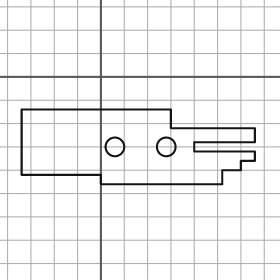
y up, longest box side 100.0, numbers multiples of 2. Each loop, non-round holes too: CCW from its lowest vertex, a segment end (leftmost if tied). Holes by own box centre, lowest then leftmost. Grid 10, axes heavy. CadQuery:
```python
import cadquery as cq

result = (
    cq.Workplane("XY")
    .moveTo(0.0, -46.0)
    .lineTo(52.0, -46.0)
    .lineTo(52.0, -40.0)
    .lineTo(60.0, -40.0)
    .lineTo(60.0, -36.0)
    .lineTo(66.0, -36.0)
    .lineTo(66.0, -32.0)
    .lineTo(40.0, -32.0)
    .lineTo(40.0, -28.0)
    .lineTo(66.0, -28.0)
    .lineTo(66.0, -22.0)
    .lineTo(30.0, -22.0)
    .lineTo(30.0, -14.0)
    .lineTo(-34.0, -14.0)
    .lineTo(-34.0, -42.0)
    .lineTo(0.0, -42.0)
    .close()
    .moveTo(6.0, -30.0)
    .circle(4.0)
    .moveTo(28.0, -30.0)
    .circle(4.0)
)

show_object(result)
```